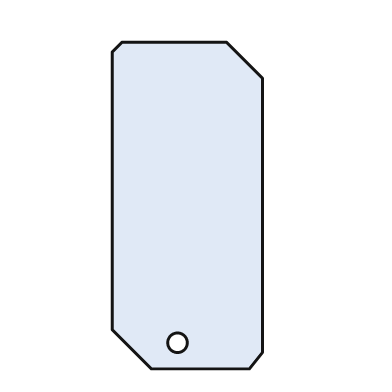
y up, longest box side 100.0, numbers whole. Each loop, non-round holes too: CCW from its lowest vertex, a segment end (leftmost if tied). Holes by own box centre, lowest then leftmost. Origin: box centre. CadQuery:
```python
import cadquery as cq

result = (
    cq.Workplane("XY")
    .moveTo(-11.0, -50.0)
    .lineTo(19.0, -50.0)
    .lineTo(23.0, -45.0)
    .lineTo(23.0, 39.0)
    .lineTo(12.0, 50.0)
    .lineTo(-20.0, 50.0)
    .lineTo(-23.0, 47.0)
    .lineTo(-23.0, -38.0)
    .close()
    .moveTo(-3.0, -42.0)
    .circle(3.0)
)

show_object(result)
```